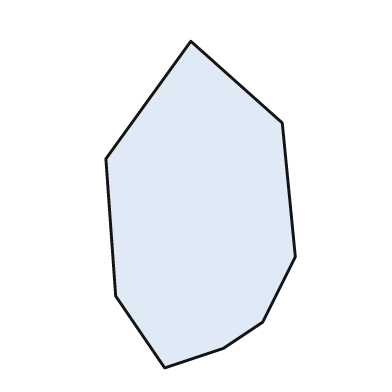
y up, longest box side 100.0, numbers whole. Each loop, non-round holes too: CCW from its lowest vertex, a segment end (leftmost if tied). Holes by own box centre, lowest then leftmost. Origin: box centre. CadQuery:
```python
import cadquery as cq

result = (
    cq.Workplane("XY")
    .moveTo(-11.0, -50.0)
    .lineTo(7.0, -44.0)
    .lineTo(19.0, -36.0)
    .lineTo(29.0, -16.0)
    .lineTo(25.0, 25.0)
    .lineTo(-3.0, 50.0)
    .lineTo(-29.0, 14.0)
    .lineTo(-26.0, -28.0)
    .close()
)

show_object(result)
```